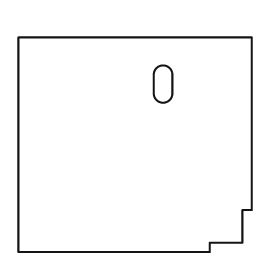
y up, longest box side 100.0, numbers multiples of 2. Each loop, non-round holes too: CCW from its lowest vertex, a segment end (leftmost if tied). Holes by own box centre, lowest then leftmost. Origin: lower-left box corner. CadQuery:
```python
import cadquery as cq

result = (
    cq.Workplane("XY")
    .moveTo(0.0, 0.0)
    .lineTo(82.0, 0.0)
    .lineTo(82.0, 4.0)
    .lineTo(96.0, 4.0)
    .lineTo(96.0, 18.0)
    .lineTo(100.0, 18.0)
    .lineTo(100.0, 92.0)
    .lineTo(0.0, 92.0)
    .close()
    .moveTo(58.0, 68.0)
    .threePointArc((62.0, 64.0), (66.0, 68.0))
    .lineTo(66.0, 76.0)
    .threePointArc((62.0, 80.0), (58.0, 76.0))
    .close()
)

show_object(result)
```